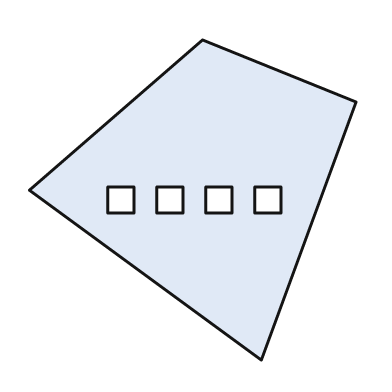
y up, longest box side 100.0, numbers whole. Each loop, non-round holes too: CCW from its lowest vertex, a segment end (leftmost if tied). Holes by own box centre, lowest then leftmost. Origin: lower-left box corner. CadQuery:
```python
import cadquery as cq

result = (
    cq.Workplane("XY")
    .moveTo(71.0, 0.0)
    .lineTo(100.0, 79.0)
    .lineTo(53.0, 98.0)
    .lineTo(0.0, 52.0)
    .close()
    .moveTo(24.0, 45.0)
    .lineTo(32.0, 45.0)
    .lineTo(32.0, 53.0)
    .lineTo(24.0, 53.0)
    .close()
    .moveTo(39.0, 45.0)
    .lineTo(47.0, 45.0)
    .lineTo(47.0, 53.0)
    .lineTo(39.0, 53.0)
    .close()
    .moveTo(54.0, 45.0)
    .lineTo(62.0, 45.0)
    .lineTo(62.0, 53.0)
    .lineTo(54.0, 53.0)
    .close()
    .moveTo(69.0, 45.0)
    .lineTo(77.0, 45.0)
    .lineTo(77.0, 53.0)
    .lineTo(69.0, 53.0)
    .close()
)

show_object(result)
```